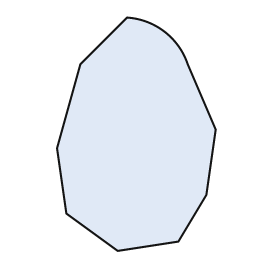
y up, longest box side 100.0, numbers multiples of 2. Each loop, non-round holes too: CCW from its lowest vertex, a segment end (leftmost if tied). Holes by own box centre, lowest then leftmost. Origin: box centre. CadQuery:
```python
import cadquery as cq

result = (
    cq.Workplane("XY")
    .moveTo(-8.0, -50.0)
    .lineTo(18.0, -46.0)
    .lineTo(30.0, -26.0)
    .lineTo(34.0, 2.0)
    .lineTo(22.0, 30.0)
    .threePointArc((12.0, 44.0), (-4.0, 50.0))
    .lineTo(-24.0, 30.0)
    .lineTo(-34.0, -6.0)
    .lineTo(-30.0, -34.0)
    .close()
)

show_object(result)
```